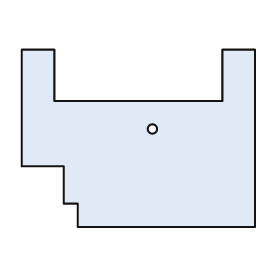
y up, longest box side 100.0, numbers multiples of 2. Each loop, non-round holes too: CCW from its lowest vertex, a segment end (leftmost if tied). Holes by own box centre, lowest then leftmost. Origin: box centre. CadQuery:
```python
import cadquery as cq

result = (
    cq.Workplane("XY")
    .moveTo(-26.0, -38.0)
    .lineTo(50.0, -38.0)
    .lineTo(50.0, 38.0)
    .lineTo(36.0, 38.0)
    .lineTo(36.0, 16.0)
    .lineTo(-36.0, 16.0)
    .lineTo(-36.0, 38.0)
    .lineTo(-50.0, 38.0)
    .lineTo(-50.0, -12.0)
    .lineTo(-32.0, -12.0)
    .lineTo(-32.0, -28.0)
    .lineTo(-26.0, -28.0)
    .close()
    .moveTo(6.0, 4.0)
    .circle(2.0)
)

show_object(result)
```